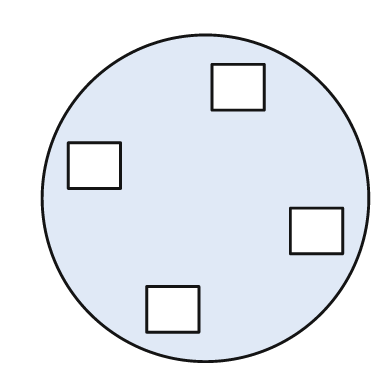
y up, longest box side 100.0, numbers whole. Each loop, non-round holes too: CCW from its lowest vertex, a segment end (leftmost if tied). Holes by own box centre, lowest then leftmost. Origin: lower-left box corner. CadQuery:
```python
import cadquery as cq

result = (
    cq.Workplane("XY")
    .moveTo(50.0, 50.0)
    .circle(50.0)
    .moveTo(32.0, 9.0)
    .lineTo(48.0, 9.0)
    .lineTo(48.0, 23.0)
    .lineTo(32.0, 23.0)
    .close()
    .moveTo(76.0, 33.0)
    .lineTo(92.0, 33.0)
    .lineTo(92.0, 47.0)
    .lineTo(76.0, 47.0)
    .close()
    .moveTo(8.0, 53.0)
    .lineTo(24.0, 53.0)
    .lineTo(24.0, 67.0)
    .lineTo(8.0, 67.0)
    .close()
    .moveTo(52.0, 77.0)
    .lineTo(68.0, 77.0)
    .lineTo(68.0, 91.0)
    .lineTo(52.0, 91.0)
    .close()
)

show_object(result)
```